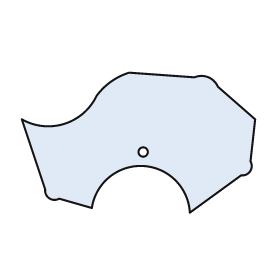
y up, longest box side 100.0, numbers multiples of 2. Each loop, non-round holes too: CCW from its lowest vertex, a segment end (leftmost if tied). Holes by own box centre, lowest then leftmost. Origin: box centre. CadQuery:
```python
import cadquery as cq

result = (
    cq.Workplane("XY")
    .moveTo(22.0, -30.0)
    .lineTo(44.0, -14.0)
    .threePointArc((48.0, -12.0), (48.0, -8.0))
    .lineTo(50.0, 10.0)
    .lineTo(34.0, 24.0)
    .threePointArc((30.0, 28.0), (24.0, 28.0))
    .lineTo(-4.0, 30.0)
    .threePointArc((-12.0, 26.0), (-18.0, 20.0))
    .threePointArc((-32.0, 8.0), (-50.0, 10.0))
    .lineTo(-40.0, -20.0)
    .threePointArc((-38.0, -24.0), (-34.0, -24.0))
    .lineTo(-20.0, -28.0)
    .threePointArc((2.0, -10.0), (22.0, -30.0))
    .close()
    .moveTo(2.0, -4.0)
    .circle(2.0)
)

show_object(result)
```